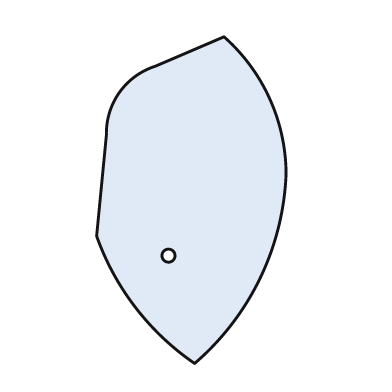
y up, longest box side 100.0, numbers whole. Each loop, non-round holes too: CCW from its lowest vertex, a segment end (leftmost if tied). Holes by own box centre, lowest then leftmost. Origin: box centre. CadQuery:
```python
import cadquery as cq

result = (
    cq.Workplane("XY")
    .moveTo(1.0, -50.0)
    .threePointArc((21.0, -24.0), (29.0, 8.0))
    .threePointArc((24.0, 31.0), (10.0, 50.0))
    .lineTo(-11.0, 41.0)
    .threePointArc((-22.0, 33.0), (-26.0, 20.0))
    .lineTo(-29.0, -11.0)
    .threePointArc((-17.0, -33.0), (1.0, -50.0))
    .close()
    .moveTo(-7.0, -17.0)
    .circle(2.0)
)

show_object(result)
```